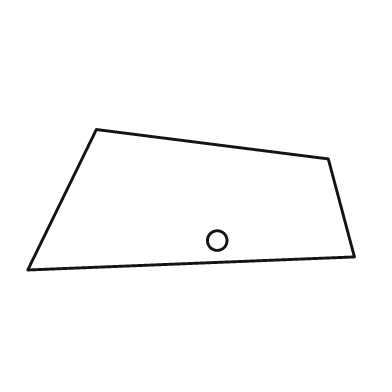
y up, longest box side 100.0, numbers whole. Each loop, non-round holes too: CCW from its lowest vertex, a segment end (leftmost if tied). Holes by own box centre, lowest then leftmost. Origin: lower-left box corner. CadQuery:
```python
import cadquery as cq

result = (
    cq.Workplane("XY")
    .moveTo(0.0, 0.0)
    .lineTo(100.0, 4.0)
    .lineTo(92.0, 34.0)
    .lineTo(21.0, 43.0)
    .close()
    .moveTo(58.0, 9.0)
    .circle(3.0)
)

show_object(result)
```